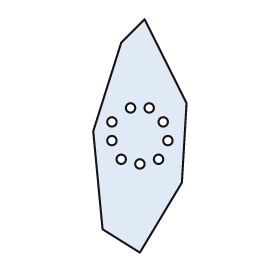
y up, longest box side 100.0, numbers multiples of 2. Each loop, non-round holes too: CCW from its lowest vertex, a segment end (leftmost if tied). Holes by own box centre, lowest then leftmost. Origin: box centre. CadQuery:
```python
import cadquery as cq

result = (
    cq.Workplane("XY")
    .moveTo(0.0, -50.0)
    .lineTo(18.0, -20.0)
    .lineTo(20.0, 14.0)
    .lineTo(2.0, 50.0)
    .lineTo(-8.0, 40.0)
    .lineTo(-20.0, 2.0)
    .lineTo(-16.0, -40.0)
    .close()
    .moveTo(0.0, -12.0)
    .circle(2.0)
    .moveTo(-8.0, -10.0)
    .circle(2.0)
    .moveTo(8.0, -10.0)
    .circle(2.0)
    .moveTo(-12.0, -2.0)
    .circle(2.0)
    .moveTo(12.0, -2.0)
    .circle(2.0)
    .moveTo(-12.0, 6.0)
    .circle(2.0)
    .moveTo(10.0, 6.0)
    .circle(2.0)
    .moveTo(-4.0, 12.0)
    .circle(2.0)
    .moveTo(4.0, 12.0)
    .circle(2.0)
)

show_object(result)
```